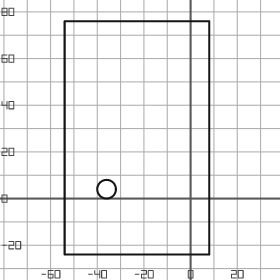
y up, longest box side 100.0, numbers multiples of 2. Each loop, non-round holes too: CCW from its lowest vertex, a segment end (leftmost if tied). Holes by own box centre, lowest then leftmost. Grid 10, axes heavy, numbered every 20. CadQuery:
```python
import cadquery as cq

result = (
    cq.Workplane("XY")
    .moveTo(-54.0, -24.0)
    .lineTo(8.0, -24.0)
    .lineTo(8.0, 76.0)
    .lineTo(-54.0, 76.0)
    .close()
    .moveTo(-36.0, 4.0)
    .circle(4.0)
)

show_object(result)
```